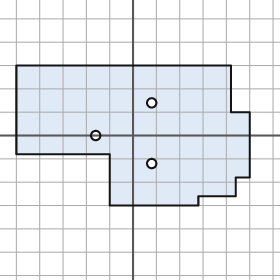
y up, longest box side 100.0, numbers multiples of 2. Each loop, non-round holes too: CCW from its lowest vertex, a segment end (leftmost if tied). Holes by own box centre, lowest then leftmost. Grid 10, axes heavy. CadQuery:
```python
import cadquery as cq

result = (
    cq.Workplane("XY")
    .moveTo(-10.0, -30.0)
    .lineTo(28.0, -30.0)
    .lineTo(28.0, -26.0)
    .lineTo(44.0, -26.0)
    .lineTo(44.0, -18.0)
    .lineTo(50.0, -18.0)
    .lineTo(50.0, 10.0)
    .lineTo(42.0, 10.0)
    .lineTo(42.0, 30.0)
    .lineTo(-50.0, 30.0)
    .lineTo(-50.0, -8.0)
    .lineTo(-10.0, -8.0)
    .close()
    .moveTo(8.0, -12.0)
    .circle(2.0)
    .moveTo(-16.0, 0.0)
    .circle(2.0)
    .moveTo(8.0, 14.0)
    .circle(2.0)
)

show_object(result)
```